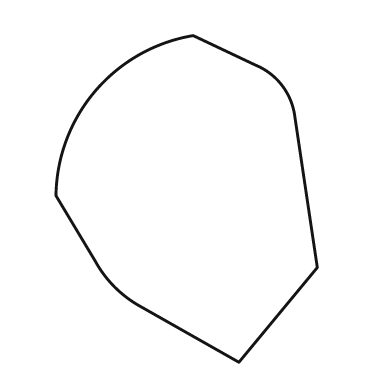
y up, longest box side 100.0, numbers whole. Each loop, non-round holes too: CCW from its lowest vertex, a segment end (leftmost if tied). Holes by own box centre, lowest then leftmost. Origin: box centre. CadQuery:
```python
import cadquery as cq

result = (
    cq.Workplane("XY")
    .moveTo(16.0, -50.0)
    .lineTo(40.0, -21.0)
    .lineTo(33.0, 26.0)
    .threePointArc((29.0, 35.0), (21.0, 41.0))
    .lineTo(2.0, 50.0)
    .threePointArc((-28.0, 33.0), (-40.0, 1.0))
    .lineTo(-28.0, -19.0)
    .threePointArc((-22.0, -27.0), (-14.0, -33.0))
    .close()
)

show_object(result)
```